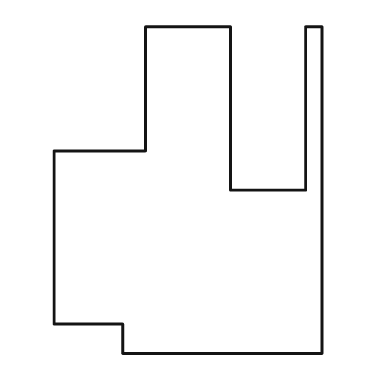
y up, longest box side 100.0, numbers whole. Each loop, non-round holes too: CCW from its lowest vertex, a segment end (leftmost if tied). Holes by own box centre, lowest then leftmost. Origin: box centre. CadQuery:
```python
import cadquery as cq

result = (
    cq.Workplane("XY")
    .moveTo(-20.0, -50.0)
    .lineTo(41.0, -50.0)
    .lineTo(41.0, 50.0)
    .lineTo(36.0, 50.0)
    .lineTo(36.0, 0.0)
    .lineTo(13.0, 0.0)
    .lineTo(13.0, 50.0)
    .lineTo(-13.0, 50.0)
    .lineTo(-13.0, 12.0)
    .lineTo(-41.0, 12.0)
    .lineTo(-41.0, -41.0)
    .lineTo(-20.0, -41.0)
    .close()
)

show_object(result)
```